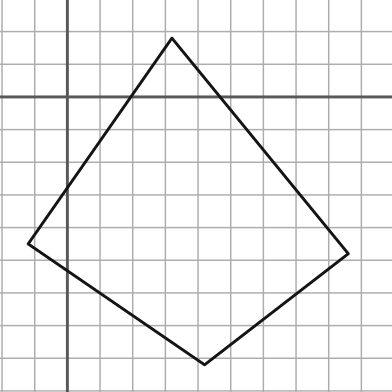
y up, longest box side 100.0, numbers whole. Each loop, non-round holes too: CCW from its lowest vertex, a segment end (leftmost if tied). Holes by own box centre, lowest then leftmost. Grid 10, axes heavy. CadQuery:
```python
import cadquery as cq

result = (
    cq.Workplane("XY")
    .moveTo(42.0, -82.0)
    .lineTo(86.0, -48.0)
    .lineTo(32.0, 18.0)
    .lineTo(-12.0, -45.0)
    .close()
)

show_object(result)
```